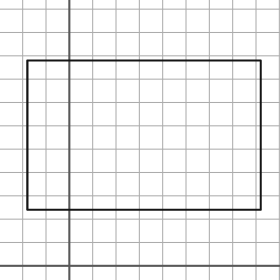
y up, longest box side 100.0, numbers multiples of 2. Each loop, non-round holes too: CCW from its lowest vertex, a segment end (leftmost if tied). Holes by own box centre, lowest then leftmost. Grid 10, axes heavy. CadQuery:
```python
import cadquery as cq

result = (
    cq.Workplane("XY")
    .moveTo(-18.0, 24.0)
    .lineTo(82.0, 24.0)
    .lineTo(82.0, 88.0)
    .lineTo(-18.0, 88.0)
    .close()
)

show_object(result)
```